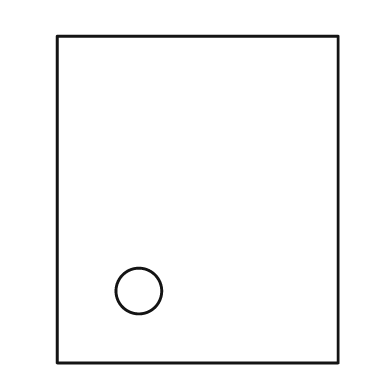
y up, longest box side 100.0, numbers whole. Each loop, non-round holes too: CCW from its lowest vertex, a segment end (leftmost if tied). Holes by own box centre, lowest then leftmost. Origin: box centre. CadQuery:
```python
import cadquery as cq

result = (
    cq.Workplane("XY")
    .moveTo(-43.0, -50.0)
    .lineTo(43.0, -50.0)
    .lineTo(43.0, 50.0)
    .lineTo(-43.0, 50.0)
    .close()
    .moveTo(-18.0, -28.0)
    .circle(7.0)
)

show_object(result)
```